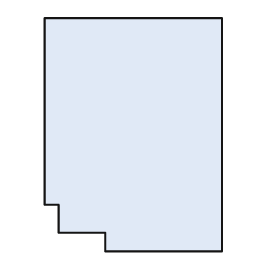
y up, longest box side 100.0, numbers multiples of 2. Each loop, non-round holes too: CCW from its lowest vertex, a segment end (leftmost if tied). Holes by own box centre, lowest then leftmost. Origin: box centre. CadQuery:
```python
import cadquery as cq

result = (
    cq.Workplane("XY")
    .moveTo(-12.0, -50.0)
    .lineTo(38.0, -50.0)
    .lineTo(38.0, 50.0)
    .lineTo(-38.0, 50.0)
    .lineTo(-38.0, -30.0)
    .lineTo(-32.0, -30.0)
    .lineTo(-32.0, -42.0)
    .lineTo(-12.0, -42.0)
    .close()
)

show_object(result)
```